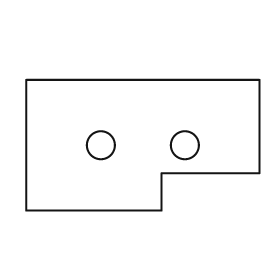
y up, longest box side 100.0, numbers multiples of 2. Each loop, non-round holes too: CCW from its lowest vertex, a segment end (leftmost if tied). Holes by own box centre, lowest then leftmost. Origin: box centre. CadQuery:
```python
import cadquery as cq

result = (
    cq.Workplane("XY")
    .moveTo(-50.0, -28.0)
    .lineTo(8.0, -28.0)
    .lineTo(8.0, -12.0)
    .lineTo(50.0, -12.0)
    .lineTo(50.0, 28.0)
    .lineTo(-50.0, 28.0)
    .close()
    .moveTo(-18.0, 0.0)
    .circle(6.0)
    .moveTo(18.0, 0.0)
    .circle(6.0)
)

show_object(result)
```